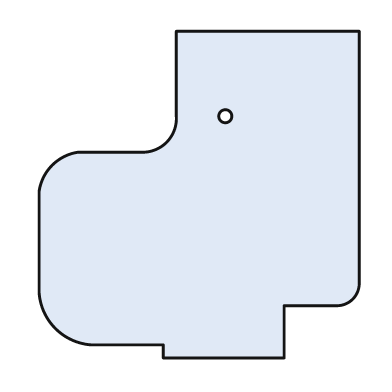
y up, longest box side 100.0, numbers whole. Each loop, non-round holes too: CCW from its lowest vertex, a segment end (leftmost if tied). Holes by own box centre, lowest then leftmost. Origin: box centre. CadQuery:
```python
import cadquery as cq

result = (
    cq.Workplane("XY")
    .moveTo(-11.0, -50.0)
    .lineTo(26.0, -50.0)
    .lineTo(26.0, -34.0)
    .lineTo(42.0, -34.0)
    .threePointArc((47.0, -32.0), (49.0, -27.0))
    .lineTo(49.0, 50.0)
    .lineTo(-7.0, 50.0)
    .lineTo(-7.0, 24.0)
    .threePointArc((-10.0, 16.0), (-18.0, 13.0))
    .lineTo(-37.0, 13.0)
    .threePointArc((-45.0, 9.0), (-49.0, 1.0))
    .lineTo(-49.0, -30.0)
    .threePointArc((-44.0, -41.0), (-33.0, -46.0))
    .lineTo(-11.0, -46.0)
    .close()
    .moveTo(8.0, 24.0)
    .circle(2.0)
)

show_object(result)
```